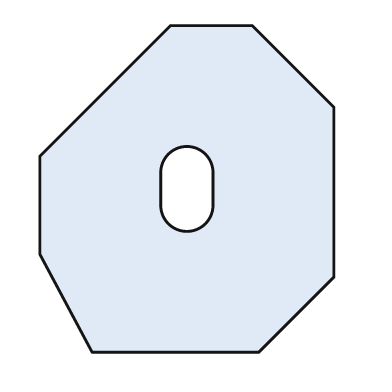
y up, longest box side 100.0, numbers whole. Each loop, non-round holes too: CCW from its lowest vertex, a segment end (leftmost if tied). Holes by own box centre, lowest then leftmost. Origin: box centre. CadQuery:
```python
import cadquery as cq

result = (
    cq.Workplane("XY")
    .moveTo(-29.0, -50.0)
    .lineTo(22.0, -50.0)
    .lineTo(45.0, -27.0)
    .lineTo(45.0, 25.0)
    .lineTo(20.0, 50.0)
    .lineTo(-5.0, 50.0)
    .lineTo(-45.0, 10.0)
    .lineTo(-45.0, -20.0)
    .close()
    .moveTo(-8.0, -5.0)
    .threePointArc((0.0, -13.0), (8.0, -5.0))
    .lineTo(8.0, 5.0)
    .threePointArc((0.0, 13.0), (-8.0, 5.0))
    .close()
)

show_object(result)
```